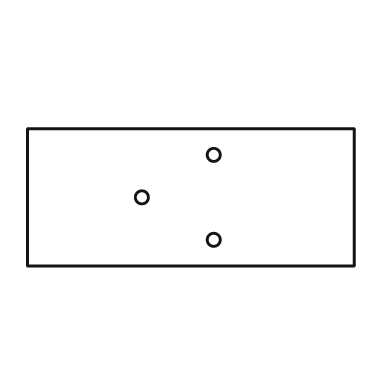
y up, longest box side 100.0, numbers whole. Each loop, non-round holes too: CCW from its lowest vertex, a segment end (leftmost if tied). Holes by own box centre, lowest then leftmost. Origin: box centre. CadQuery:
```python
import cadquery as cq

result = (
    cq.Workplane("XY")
    .moveTo(-50.0, -21.0)
    .lineTo(50.0, -21.0)
    .lineTo(50.0, 21.0)
    .lineTo(-50.0, 21.0)
    .close()
    .moveTo(7.0, -13.0)
    .circle(2.0)
    .moveTo(-15.0, 0.0)
    .circle(2.0)
    .moveTo(7.0, 13.0)
    .circle(2.0)
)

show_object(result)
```